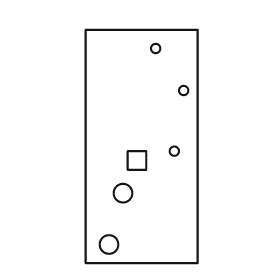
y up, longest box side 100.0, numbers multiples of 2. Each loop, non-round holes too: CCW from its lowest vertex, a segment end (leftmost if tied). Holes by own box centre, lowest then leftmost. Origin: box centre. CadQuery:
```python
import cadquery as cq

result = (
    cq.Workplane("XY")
    .moveTo(-24.0, -50.0)
    .lineTo(24.0, -50.0)
    .lineTo(24.0, 50.0)
    .lineTo(-24.0, 50.0)
    .close()
    .moveTo(-14.0, -42.0)
    .circle(4.0)
    .moveTo(-8.0, -20.0)
    .circle(4.0)
    .moveTo(-6.0, -10.0)
    .lineTo(2.0, -10.0)
    .lineTo(2.0, -2.0)
    .lineTo(-6.0, -2.0)
    .close()
    .moveTo(14.0, -2.0)
    .circle(2.0)
    .moveTo(18.0, 24.0)
    .circle(2.0)
    .moveTo(6.0, 42.0)
    .circle(2.0)
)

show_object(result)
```